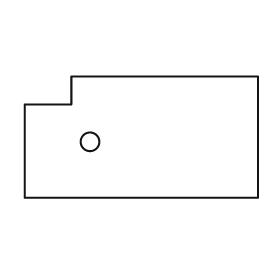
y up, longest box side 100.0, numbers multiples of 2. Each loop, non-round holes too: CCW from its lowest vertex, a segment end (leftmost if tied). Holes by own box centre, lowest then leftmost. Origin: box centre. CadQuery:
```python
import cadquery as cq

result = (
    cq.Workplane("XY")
    .moveTo(-50.0, -26.0)
    .lineTo(50.0, -26.0)
    .lineTo(50.0, 26.0)
    .lineTo(-30.0, 26.0)
    .lineTo(-30.0, 14.0)
    .lineTo(-50.0, 14.0)
    .close()
    .moveTo(-22.0, -2.0)
    .circle(4.0)
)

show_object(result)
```